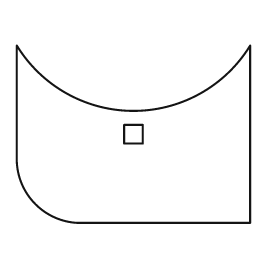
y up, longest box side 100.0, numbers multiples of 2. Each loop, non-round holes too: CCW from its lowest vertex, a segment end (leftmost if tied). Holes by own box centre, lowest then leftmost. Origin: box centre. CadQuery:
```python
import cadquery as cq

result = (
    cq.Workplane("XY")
    .moveTo(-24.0, -38.0)
    .lineTo(50.0, -38.0)
    .lineTo(50.0, 38.0)
    .threePointArc((0.0, 10.0), (-50.0, 38.0))
    .lineTo(-50.0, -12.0)
    .threePointArc((-42.0, -30.0), (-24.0, -38.0))
    .close()
    .moveTo(-4.0, -4.0)
    .lineTo(4.0, -4.0)
    .lineTo(4.0, 4.0)
    .lineTo(-4.0, 4.0)
    .close()
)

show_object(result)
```